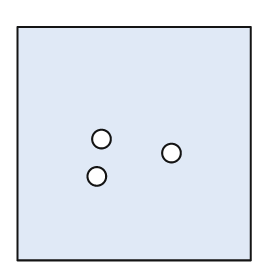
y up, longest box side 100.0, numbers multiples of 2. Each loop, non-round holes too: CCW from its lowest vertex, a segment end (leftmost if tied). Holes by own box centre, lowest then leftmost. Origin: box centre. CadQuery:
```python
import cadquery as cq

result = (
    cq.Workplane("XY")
    .moveTo(-50.0, -50.0)
    .lineTo(50.0, -50.0)
    .lineTo(50.0, 50.0)
    .lineTo(-50.0, 50.0)
    .close()
    .moveTo(-16.0, -14.0)
    .circle(4.0)
    .moveTo(16.0, -4.0)
    .circle(4.0)
    .moveTo(-14.0, 2.0)
    .circle(4.0)
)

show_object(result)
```